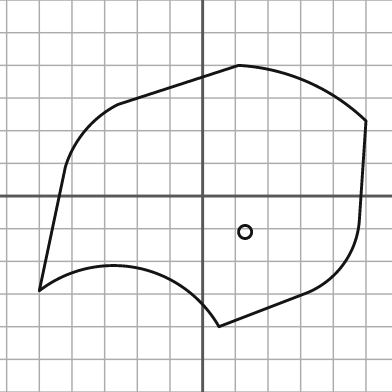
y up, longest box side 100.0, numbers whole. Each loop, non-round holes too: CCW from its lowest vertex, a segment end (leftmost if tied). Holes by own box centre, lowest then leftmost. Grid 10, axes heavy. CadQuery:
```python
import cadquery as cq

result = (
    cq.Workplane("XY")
    .moveTo(5.0, -40.0)
    .lineTo(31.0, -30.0)
    .threePointArc((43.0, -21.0), (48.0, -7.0))
    .lineTo(50.0, 23.0)
    .threePointArc((32.0, 35.0), (11.0, 40.0))
    .lineTo(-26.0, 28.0)
    .threePointArc((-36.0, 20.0), (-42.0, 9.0))
    .lineTo(-50.0, -29.0)
    .threePointArc((-20.0, -22.0), (5.0, -40.0))
    .close()
    .moveTo(13.0, -11.0)
    .circle(2.0)
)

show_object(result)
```